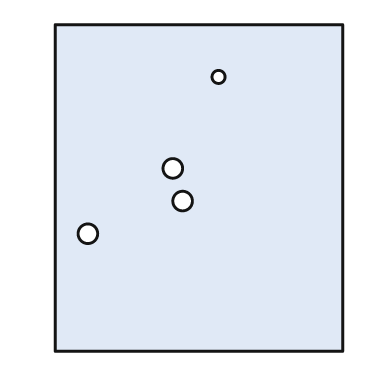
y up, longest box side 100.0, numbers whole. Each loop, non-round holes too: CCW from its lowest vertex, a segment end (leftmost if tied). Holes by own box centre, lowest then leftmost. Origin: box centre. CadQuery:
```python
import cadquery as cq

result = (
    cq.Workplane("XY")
    .moveTo(-44.0, -50.0)
    .lineTo(44.0, -50.0)
    .lineTo(44.0, 50.0)
    .lineTo(-44.0, 50.0)
    .close()
    .moveTo(-34.0, -14.0)
    .circle(3.0)
    .moveTo(-5.0, -4.0)
    .circle(3.0)
    .moveTo(-8.0, 6.0)
    .circle(3.0)
    .moveTo(6.0, 34.0)
    .circle(2.0)
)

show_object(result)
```